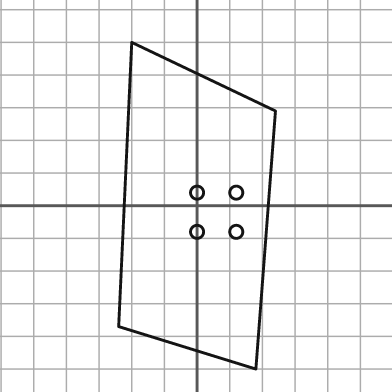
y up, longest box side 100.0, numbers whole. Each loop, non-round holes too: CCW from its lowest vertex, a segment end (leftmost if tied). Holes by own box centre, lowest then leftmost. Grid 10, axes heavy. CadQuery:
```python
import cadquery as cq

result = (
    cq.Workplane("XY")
    .moveTo(18.0, -50.0)
    .lineTo(24.0, 29.0)
    .lineTo(-20.0, 50.0)
    .lineTo(-24.0, -37.0)
    .close()
    .moveTo(0.0, -8.0)
    .circle(2.0)
    .moveTo(12.0, -8.0)
    .circle(2.0)
    .moveTo(0.0, 4.0)
    .circle(2.0)
    .moveTo(12.0, 4.0)
    .circle(2.0)
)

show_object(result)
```